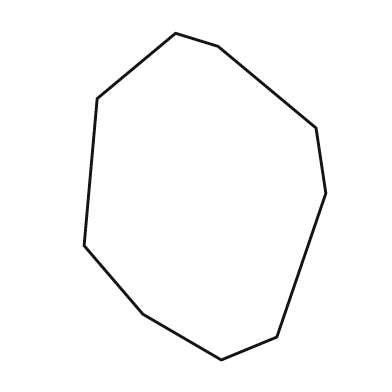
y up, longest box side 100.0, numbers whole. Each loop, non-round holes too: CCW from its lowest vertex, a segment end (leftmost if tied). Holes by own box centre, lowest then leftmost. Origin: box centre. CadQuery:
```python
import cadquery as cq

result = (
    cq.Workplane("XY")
    .moveTo(5.0, -50.0)
    .lineTo(22.0, -43.0)
    .lineTo(37.0, 1.0)
    .lineTo(34.0, 21.0)
    .lineTo(4.0, 46.0)
    .lineTo(-9.0, 50.0)
    .lineTo(-33.0, 30.0)
    .lineTo(-37.0, -15.0)
    .lineTo(-19.0, -36.0)
    .close()
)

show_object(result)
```